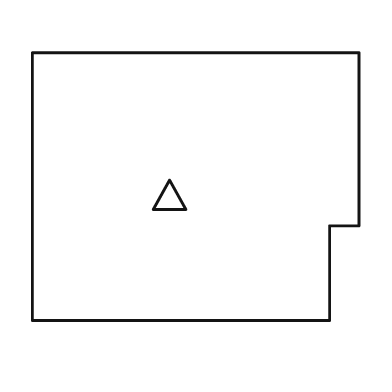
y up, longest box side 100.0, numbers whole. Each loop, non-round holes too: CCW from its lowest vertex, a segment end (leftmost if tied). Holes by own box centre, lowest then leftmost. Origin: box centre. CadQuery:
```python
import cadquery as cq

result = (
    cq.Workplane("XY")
    .moveTo(-50.0, -41.0)
    .lineTo(41.0, -41.0)
    .lineTo(41.0, -12.0)
    .lineTo(50.0, -12.0)
    .lineTo(50.0, 41.0)
    .lineTo(-50.0, 41.0)
    .close()
    .moveTo(-13.0, -7.0)
    .lineTo(-3.0, -7.0)
    .lineTo(-8.0, 2.0)
    .close()
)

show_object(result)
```